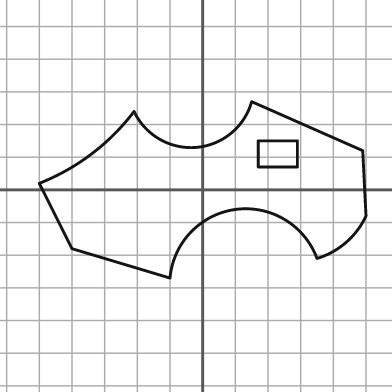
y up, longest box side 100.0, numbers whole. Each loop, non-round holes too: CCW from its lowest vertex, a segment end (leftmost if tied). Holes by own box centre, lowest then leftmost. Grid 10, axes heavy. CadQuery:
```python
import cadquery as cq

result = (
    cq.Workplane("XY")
    .moveTo(-10.0, -27.0)
    .threePointArc((10.0, -6.0), (35.0, -21.0))
    .threePointArc((44.0, -16.0), (50.0, -8.0))
    .lineTo(49.0, 12.0)
    .lineTo(15.0, 27.0)
    .threePointArc((-2.0, 13.0), (-21.0, 24.0))
    .threePointArc((-34.0, 11.0), (-50.0, 2.0))
    .lineTo(-40.0, -18.0)
    .close()
    .moveTo(17.0, 7.0)
    .lineTo(29.0, 7.0)
    .lineTo(29.0, 15.0)
    .lineTo(17.0, 15.0)
    .close()
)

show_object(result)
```